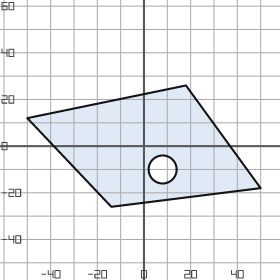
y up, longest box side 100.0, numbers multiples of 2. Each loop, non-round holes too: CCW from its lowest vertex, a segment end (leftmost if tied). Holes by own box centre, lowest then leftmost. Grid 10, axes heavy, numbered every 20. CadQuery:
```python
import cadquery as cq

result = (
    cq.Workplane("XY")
    .moveTo(-14.0, -26.0)
    .lineTo(50.0, -18.0)
    .lineTo(18.0, 26.0)
    .lineTo(-50.0, 12.0)
    .close()
    .moveTo(8.0, -10.0)
    .circle(6.0)
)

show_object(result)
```